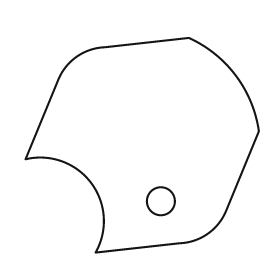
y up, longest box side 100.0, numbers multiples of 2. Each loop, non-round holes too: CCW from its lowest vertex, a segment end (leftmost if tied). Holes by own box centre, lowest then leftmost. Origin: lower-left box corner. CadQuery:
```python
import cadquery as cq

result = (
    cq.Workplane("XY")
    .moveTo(30.0, 0.0)
    .lineTo(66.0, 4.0)
    .threePointArc((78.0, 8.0), (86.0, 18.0))
    .lineTo(100.0, 52.0)
    .threePointArc((90.0, 76.0), (70.0, 92.0))
    .lineTo(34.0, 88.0)
    .threePointArc((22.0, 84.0), (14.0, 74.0))
    .lineTo(0.0, 40.0)
    .threePointArc((28.0, 30.0), (30.0, 0.0))
    .close()
    .moveTo(58.0, 22.0)
    .circle(6.0)
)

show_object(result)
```